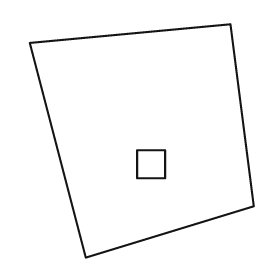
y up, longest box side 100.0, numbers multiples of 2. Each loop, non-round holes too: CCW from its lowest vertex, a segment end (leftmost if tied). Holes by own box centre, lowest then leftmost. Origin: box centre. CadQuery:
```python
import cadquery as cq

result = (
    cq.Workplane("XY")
    .moveTo(-24.0, -50.0)
    .lineTo(48.0, -28.0)
    .lineTo(38.0, 50.0)
    .lineTo(-48.0, 42.0)
    .close()
    .moveTo(-2.0, -16.0)
    .lineTo(10.0, -16.0)
    .lineTo(10.0, -4.0)
    .lineTo(-2.0, -4.0)
    .close()
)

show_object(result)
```